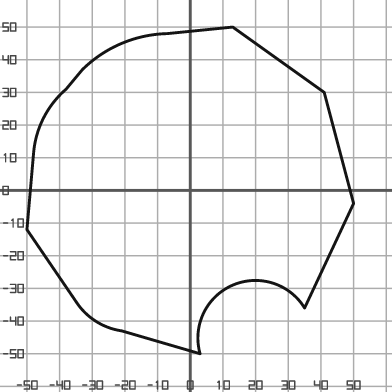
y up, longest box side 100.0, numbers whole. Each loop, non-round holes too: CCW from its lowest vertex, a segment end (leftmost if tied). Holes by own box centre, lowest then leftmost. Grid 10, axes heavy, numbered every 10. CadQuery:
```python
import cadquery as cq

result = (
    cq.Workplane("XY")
    .moveTo(3.0, -50.0)
    .threePointArc((13.0, -29.0), (35.0, -36.0))
    .lineTo(50.0, -4.0)
    .lineTo(41.0, 30.0)
    .lineTo(13.0, 50.0)
    .lineTo(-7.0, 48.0)
    .threePointArc((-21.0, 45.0), (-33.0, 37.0))
    .lineTo(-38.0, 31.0)
    .threePointArc((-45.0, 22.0), (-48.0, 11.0))
    .lineTo(-50.0, -12.0)
    .lineTo(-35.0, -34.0)
    .threePointArc((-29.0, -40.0), (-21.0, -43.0))
    .close()
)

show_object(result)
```